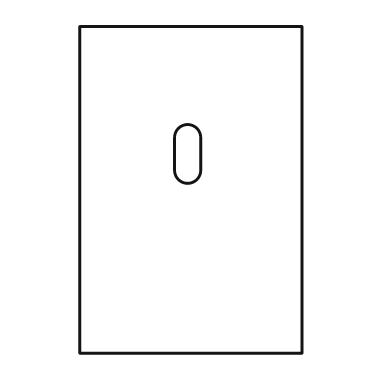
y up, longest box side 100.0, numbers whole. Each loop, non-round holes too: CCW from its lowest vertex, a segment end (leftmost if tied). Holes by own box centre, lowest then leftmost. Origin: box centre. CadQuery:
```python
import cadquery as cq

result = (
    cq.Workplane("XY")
    .moveTo(-34.0, -50.0)
    .lineTo(34.0, -50.0)
    .lineTo(34.0, 50.0)
    .lineTo(-34.0, 50.0)
    .close()
    .moveTo(-5.0, 6.0)
    .threePointArc((-1.0, 2.0), (3.0, 6.0))
    .lineTo(3.0, 16.0)
    .threePointArc((-1.0, 20.0), (-5.0, 16.0))
    .close()
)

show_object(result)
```